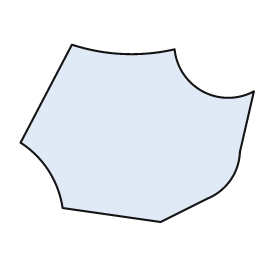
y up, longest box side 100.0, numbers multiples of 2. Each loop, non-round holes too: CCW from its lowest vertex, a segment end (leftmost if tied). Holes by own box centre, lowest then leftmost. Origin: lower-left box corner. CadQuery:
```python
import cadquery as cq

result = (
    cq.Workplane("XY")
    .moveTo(60.0, 0.0)
    .lineTo(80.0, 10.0)
    .threePointArc((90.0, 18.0), (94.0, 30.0))
    .lineTo(100.0, 56.0)
    .threePointArc((78.0, 56.0), (66.0, 74.0))
    .threePointArc((44.0, 72.0), (22.0, 76.0))
    .lineTo(0.0, 34.0)
    .threePointArc((12.0, 22.0), (18.0, 6.0))
    .close()
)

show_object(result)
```